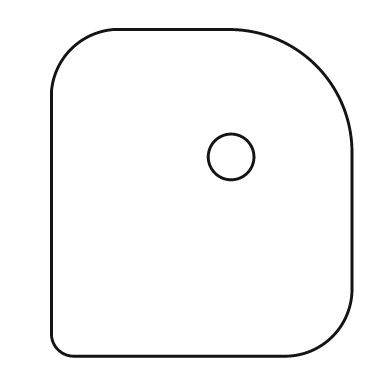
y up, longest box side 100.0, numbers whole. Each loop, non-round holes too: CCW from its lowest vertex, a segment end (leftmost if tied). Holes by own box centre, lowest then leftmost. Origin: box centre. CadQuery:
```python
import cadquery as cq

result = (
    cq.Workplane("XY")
    .moveTo(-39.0, -50.0)
    .lineTo(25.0, -50.0)
    .threePointArc((40.0, -44.0), (46.0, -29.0))
    .lineTo(46.0, 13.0)
    .threePointArc((35.0, 39.0), (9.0, 50.0))
    .lineTo(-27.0, 50.0)
    .threePointArc((-40.0, 44.0), (-46.0, 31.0))
    .lineTo(-46.0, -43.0)
    .threePointArc((-44.0, -48.0), (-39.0, -50.0))
    .close()
    .moveTo(9.0, 11.0)
    .circle(7.0)
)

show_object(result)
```